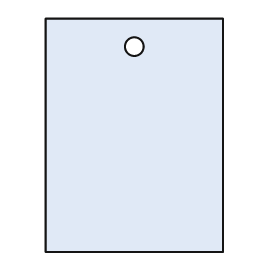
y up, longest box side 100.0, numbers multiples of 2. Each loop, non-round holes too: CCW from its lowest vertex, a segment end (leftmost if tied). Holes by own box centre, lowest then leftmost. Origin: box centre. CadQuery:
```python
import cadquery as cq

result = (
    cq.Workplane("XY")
    .moveTo(-38.0, -50.0)
    .lineTo(38.0, -50.0)
    .lineTo(38.0, 50.0)
    .lineTo(-38.0, 50.0)
    .close()
    .moveTo(0.0, 38.0)
    .circle(4.0)
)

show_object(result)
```